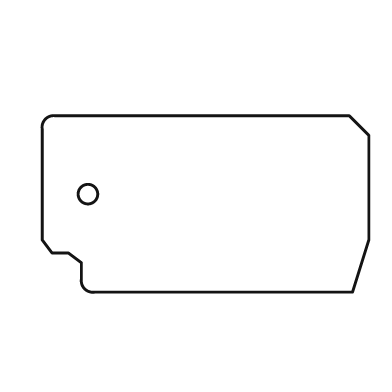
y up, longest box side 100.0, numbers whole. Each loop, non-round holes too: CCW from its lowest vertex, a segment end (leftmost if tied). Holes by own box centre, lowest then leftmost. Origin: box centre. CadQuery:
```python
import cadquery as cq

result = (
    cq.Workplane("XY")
    .moveTo(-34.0, -27.0)
    .lineTo(45.0, -27.0)
    .lineTo(50.0, -11.0)
    .lineTo(50.0, 21.0)
    .lineTo(44.0, 27.0)
    .lineTo(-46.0, 27.0)
    .threePointArc((-49.0, 26.0), (-50.0, 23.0))
    .lineTo(-50.0, -11.0)
    .lineTo(-47.0, -15.0)
    .lineTo(-42.0, -15.0)
    .lineTo(-38.0, -18.0)
    .lineTo(-38.0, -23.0)
    .threePointArc((-37.0, -26.0), (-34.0, -27.0))
    .close()
    .moveTo(-36.0, 3.0)
    .circle(3.0)
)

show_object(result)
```